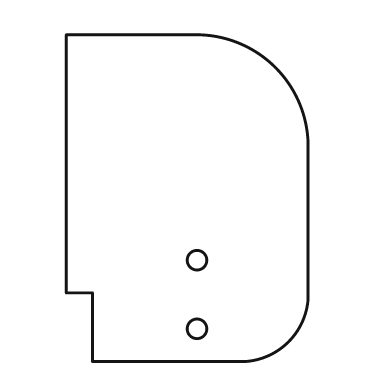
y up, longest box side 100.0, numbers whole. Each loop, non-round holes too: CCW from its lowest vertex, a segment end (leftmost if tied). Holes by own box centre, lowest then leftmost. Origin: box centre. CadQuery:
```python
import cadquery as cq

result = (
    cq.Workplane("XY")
    .moveTo(-29.0, -50.0)
    .lineTo(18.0, -50.0)
    .threePointArc((31.0, -44.0), (37.0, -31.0))
    .lineTo(37.0, 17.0)
    .threePointArc((27.0, 40.0), (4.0, 50.0))
    .lineTo(-37.0, 50.0)
    .lineTo(-37.0, -29.0)
    .lineTo(-29.0, -29.0)
    .close()
    .moveTo(3.0, -40.0)
    .circle(3.0)
    .moveTo(3.0, -19.0)
    .circle(3.0)
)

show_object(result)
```